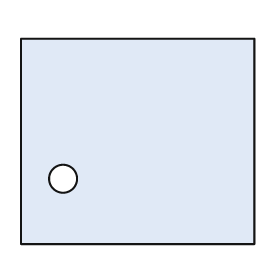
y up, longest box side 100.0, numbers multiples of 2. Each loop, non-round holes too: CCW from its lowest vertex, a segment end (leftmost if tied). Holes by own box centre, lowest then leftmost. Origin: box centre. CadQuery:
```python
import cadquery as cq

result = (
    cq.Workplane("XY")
    .moveTo(-50.0, -44.0)
    .lineTo(50.0, -44.0)
    .lineTo(50.0, 44.0)
    .lineTo(-50.0, 44.0)
    .close()
    .moveTo(-32.0, -16.0)
    .circle(6.0)
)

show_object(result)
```